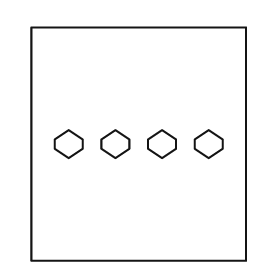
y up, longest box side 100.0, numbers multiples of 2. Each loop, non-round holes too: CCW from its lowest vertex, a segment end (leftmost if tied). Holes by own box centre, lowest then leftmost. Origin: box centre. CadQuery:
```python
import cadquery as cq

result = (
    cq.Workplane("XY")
    .moveTo(-46.0, -50.0)
    .lineTo(46.0, -50.0)
    .lineTo(46.0, 50.0)
    .lineTo(-46.0, 50.0)
    .close()
    .moveTo(-30.0, -6.0)
    .lineTo(-24.0, -2.0)
    .lineTo(-24.0, 2.0)
    .lineTo(-30.0, 6.0)
    .lineTo(-36.0, 2.0)
    .lineTo(-36.0, -2.0)
    .close()
    .moveTo(-10.0, -6.0)
    .lineTo(-4.0, -2.0)
    .lineTo(-4.0, 2.0)
    .lineTo(-10.0, 6.0)
    .lineTo(-16.0, 2.0)
    .lineTo(-16.0, -2.0)
    .close()
    .moveTo(10.0, -6.0)
    .lineTo(16.0, -2.0)
    .lineTo(16.0, 2.0)
    .lineTo(10.0, 6.0)
    .lineTo(4.0, 2.0)
    .lineTo(4.0, -2.0)
    .close()
    .moveTo(30.0, -6.0)
    .lineTo(36.0, -2.0)
    .lineTo(36.0, 2.0)
    .lineTo(30.0, 6.0)
    .lineTo(24.0, 2.0)
    .lineTo(24.0, -2.0)
    .close()
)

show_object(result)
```